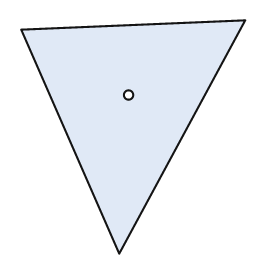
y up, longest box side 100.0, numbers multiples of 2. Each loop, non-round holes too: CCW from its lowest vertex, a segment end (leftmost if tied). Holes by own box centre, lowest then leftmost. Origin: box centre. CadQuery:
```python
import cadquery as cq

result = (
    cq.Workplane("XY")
    .moveTo(-6.0, -50.0)
    .lineTo(48.0, 50.0)
    .lineTo(-48.0, 46.0)
    .close()
    .moveTo(-2.0, 18.0)
    .circle(2.0)
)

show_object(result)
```